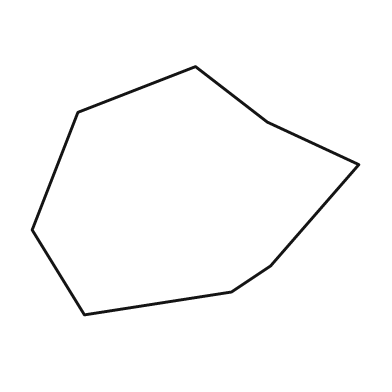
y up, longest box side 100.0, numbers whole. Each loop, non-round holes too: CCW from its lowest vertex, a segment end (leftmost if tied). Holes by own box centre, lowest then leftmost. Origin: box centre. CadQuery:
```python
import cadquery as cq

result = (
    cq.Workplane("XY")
    .moveTo(-34.0, -38.0)
    .lineTo(11.0, -31.0)
    .lineTo(23.0, -23.0)
    .lineTo(50.0, 8.0)
    .lineTo(22.0, 21.0)
    .lineTo(0.0, 38.0)
    .lineTo(-36.0, 24.0)
    .lineTo(-50.0, -12.0)
    .close()
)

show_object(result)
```